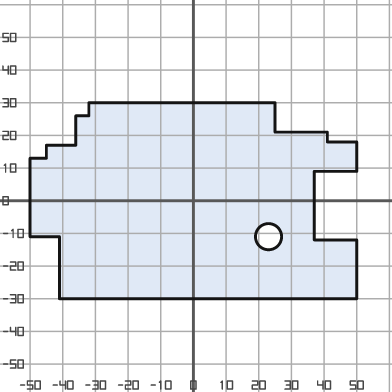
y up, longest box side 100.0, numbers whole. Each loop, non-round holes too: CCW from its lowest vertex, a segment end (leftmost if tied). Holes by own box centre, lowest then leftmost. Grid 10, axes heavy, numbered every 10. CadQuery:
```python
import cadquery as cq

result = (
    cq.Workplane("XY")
    .moveTo(-41.0, -30.0)
    .lineTo(50.0, -30.0)
    .lineTo(50.0, -12.0)
    .lineTo(37.0, -12.0)
    .lineTo(37.0, 9.0)
    .lineTo(50.0, 9.0)
    .lineTo(50.0, 18.0)
    .lineTo(41.0, 18.0)
    .lineTo(41.0, 21.0)
    .lineTo(25.0, 21.0)
    .lineTo(25.0, 30.0)
    .lineTo(-32.0, 30.0)
    .lineTo(-32.0, 26.0)
    .lineTo(-36.0, 26.0)
    .lineTo(-36.0, 17.0)
    .lineTo(-45.0, 17.0)
    .lineTo(-45.0, 13.0)
    .lineTo(-50.0, 13.0)
    .lineTo(-50.0, -11.0)
    .lineTo(-41.0, -11.0)
    .close()
    .moveTo(23.0, -11.0)
    .circle(4.0)
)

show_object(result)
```